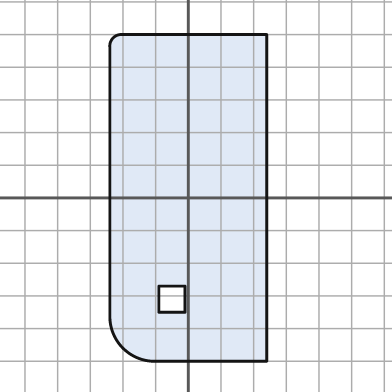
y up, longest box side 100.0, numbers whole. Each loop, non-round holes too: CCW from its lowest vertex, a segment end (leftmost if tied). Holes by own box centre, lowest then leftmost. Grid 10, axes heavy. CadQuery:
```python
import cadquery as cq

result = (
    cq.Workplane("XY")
    .moveTo(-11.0, -50.0)
    .lineTo(24.0, -50.0)
    .lineTo(24.0, 50.0)
    .lineTo(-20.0, 50.0)
    .threePointArc((-23.0, 49.0), (-24.0, 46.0))
    .lineTo(-24.0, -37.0)
    .threePointArc((-20.0, -46.0), (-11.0, -50.0))
    .close()
    .moveTo(-9.0, -35.0)
    .lineTo(-1.0, -35.0)
    .lineTo(-1.0, -27.0)
    .lineTo(-9.0, -27.0)
    .close()
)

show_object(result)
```